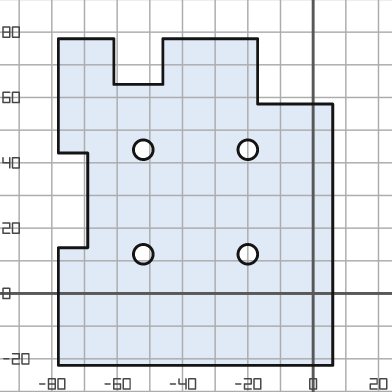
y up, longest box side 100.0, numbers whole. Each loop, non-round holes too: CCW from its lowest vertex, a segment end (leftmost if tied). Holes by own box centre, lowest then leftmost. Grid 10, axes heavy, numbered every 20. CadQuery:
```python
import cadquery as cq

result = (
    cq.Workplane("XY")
    .moveTo(-78.0, -22.0)
    .lineTo(6.0, -22.0)
    .lineTo(6.0, 58.0)
    .lineTo(-17.0, 58.0)
    .lineTo(-17.0, 78.0)
    .lineTo(-46.0, 78.0)
    .lineTo(-46.0, 64.0)
    .lineTo(-61.0, 64.0)
    .lineTo(-61.0, 78.0)
    .lineTo(-78.0, 78.0)
    .lineTo(-78.0, 43.0)
    .lineTo(-69.0, 43.0)
    .lineTo(-69.0, 14.0)
    .lineTo(-78.0, 14.0)
    .close()
    .moveTo(-52.0, 12.0)
    .circle(3.0)
    .moveTo(-20.0, 12.0)
    .circle(3.0)
    .moveTo(-52.0, 44.0)
    .circle(3.0)
    .moveTo(-20.0, 44.0)
    .circle(3.0)
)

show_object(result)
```